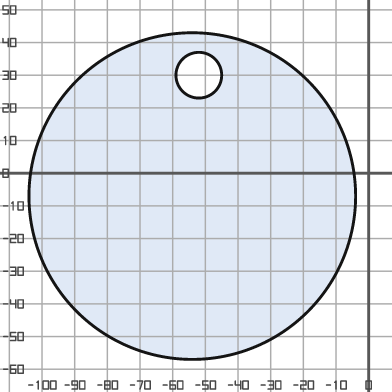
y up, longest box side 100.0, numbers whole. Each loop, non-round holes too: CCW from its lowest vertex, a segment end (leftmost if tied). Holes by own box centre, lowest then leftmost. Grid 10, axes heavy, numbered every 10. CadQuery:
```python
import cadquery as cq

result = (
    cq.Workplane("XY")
    .moveTo(-54.0, -7.0)
    .circle(50.0)
    .moveTo(-52.0, 30.0)
    .circle(7.0)
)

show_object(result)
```